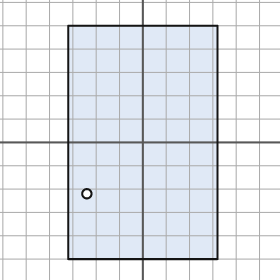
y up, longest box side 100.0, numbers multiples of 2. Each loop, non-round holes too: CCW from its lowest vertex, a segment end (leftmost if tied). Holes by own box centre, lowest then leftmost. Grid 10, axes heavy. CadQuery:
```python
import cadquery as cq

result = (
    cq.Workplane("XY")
    .moveTo(-32.0, -50.0)
    .lineTo(32.0, -50.0)
    .lineTo(32.0, 50.0)
    .lineTo(-32.0, 50.0)
    .close()
    .moveTo(-24.0, -22.0)
    .circle(2.0)
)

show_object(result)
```